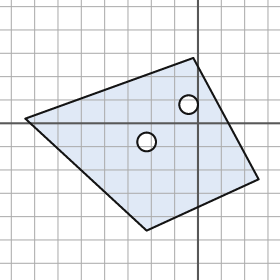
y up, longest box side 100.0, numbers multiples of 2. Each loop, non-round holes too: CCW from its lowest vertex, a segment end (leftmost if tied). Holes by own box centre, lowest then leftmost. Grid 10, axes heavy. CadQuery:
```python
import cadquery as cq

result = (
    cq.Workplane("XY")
    .moveTo(-22.0, -46.0)
    .lineTo(26.0, -24.0)
    .lineTo(-2.0, 28.0)
    .lineTo(-74.0, 2.0)
    .close()
    .moveTo(-22.0, -8.0)
    .circle(4.0)
    .moveTo(-4.0, 8.0)
    .circle(4.0)
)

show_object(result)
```